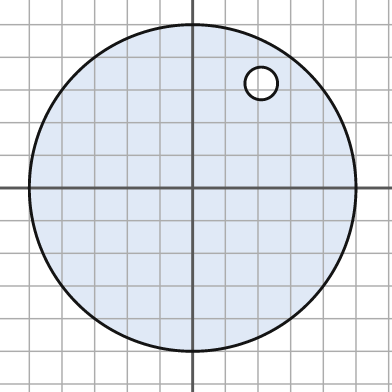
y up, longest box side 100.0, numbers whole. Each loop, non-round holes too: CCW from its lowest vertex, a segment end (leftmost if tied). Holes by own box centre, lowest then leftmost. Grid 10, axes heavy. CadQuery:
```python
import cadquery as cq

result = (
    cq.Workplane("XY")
    .moveTo(0.0, 0.0)
    .circle(50.0)
    .moveTo(21.0, 32.0)
    .circle(5.0)
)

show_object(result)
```